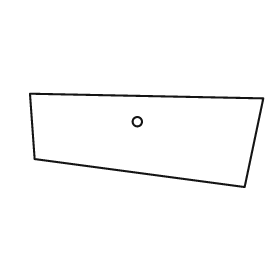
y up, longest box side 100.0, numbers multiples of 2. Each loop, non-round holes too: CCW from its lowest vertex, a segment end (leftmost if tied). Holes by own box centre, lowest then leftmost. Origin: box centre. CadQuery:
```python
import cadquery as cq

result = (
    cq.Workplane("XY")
    .moveTo(42.0, -20.0)
    .lineTo(50.0, 18.0)
    .lineTo(-50.0, 20.0)
    .lineTo(-48.0, -8.0)
    .close()
    .moveTo(-4.0, 8.0)
    .circle(2.0)
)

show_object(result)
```